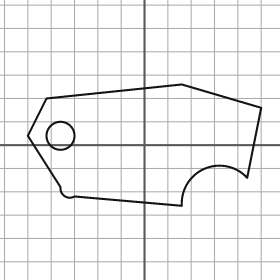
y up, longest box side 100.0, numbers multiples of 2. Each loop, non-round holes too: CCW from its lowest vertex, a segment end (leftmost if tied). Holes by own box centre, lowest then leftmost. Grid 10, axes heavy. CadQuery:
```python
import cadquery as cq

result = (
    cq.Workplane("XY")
    .moveTo(16.0, -26.0)
    .threePointArc((26.0, -10.0), (44.0, -14.0))
    .lineTo(50.0, 16.0)
    .lineTo(16.0, 26.0)
    .lineTo(-42.0, 20.0)
    .lineTo(-50.0, 4.0)
    .lineTo(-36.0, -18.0)
    .threePointArc((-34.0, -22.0), (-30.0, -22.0))
    .close()
    .moveTo(-36.0, 4.0)
    .circle(6.0)
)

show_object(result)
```